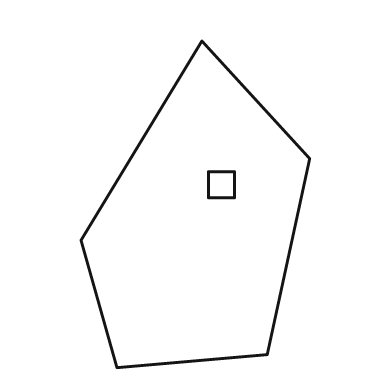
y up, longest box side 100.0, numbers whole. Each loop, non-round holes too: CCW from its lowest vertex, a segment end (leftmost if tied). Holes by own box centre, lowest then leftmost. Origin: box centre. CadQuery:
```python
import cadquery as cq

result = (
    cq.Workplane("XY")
    .moveTo(-24.0, -50.0)
    .lineTo(22.0, -46.0)
    .lineTo(35.0, 14.0)
    .lineTo(2.0, 50.0)
    .lineTo(-35.0, -11.0)
    .close()
    .moveTo(4.0, 2.0)
    .lineTo(12.0, 2.0)
    .lineTo(12.0, 10.0)
    .lineTo(4.0, 10.0)
    .close()
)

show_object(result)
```